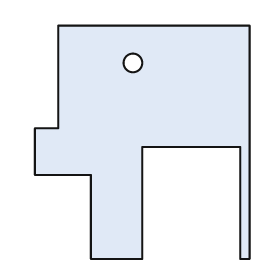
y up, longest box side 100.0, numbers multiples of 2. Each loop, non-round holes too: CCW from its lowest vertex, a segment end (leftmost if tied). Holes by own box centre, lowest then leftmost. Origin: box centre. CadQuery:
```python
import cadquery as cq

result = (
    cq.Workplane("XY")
    .moveTo(-22.0, -50.0)
    .lineTo(0.0, -50.0)
    .lineTo(0.0, -2.0)
    .lineTo(42.0, -2.0)
    .lineTo(42.0, -50.0)
    .lineTo(46.0, -50.0)
    .lineTo(46.0, 50.0)
    .lineTo(-36.0, 50.0)
    .lineTo(-36.0, 6.0)
    .lineTo(-46.0, 6.0)
    .lineTo(-46.0, -14.0)
    .lineTo(-22.0, -14.0)
    .close()
    .moveTo(-4.0, 34.0)
    .circle(4.0)
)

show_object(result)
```